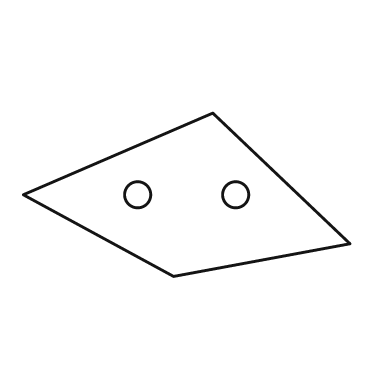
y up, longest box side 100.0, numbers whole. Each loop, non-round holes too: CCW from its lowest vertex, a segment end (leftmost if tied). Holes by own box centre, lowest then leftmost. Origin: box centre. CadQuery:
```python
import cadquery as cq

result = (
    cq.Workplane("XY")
    .moveTo(-4.0, -25.0)
    .lineTo(50.0, -15.0)
    .lineTo(8.0, 25.0)
    .lineTo(-50.0, 0.0)
    .close()
    .moveTo(-15.0, 0.0)
    .circle(4.0)
    .moveTo(15.0, 0.0)
    .circle(4.0)
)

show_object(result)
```